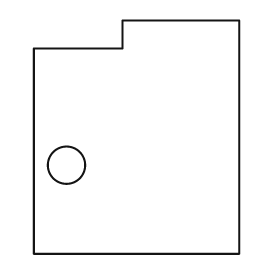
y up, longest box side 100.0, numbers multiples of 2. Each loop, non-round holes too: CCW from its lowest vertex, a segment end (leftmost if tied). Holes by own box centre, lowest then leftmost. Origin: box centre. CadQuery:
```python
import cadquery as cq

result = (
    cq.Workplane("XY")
    .moveTo(-44.0, -50.0)
    .lineTo(44.0, -50.0)
    .lineTo(44.0, 50.0)
    .lineTo(-6.0, 50.0)
    .lineTo(-6.0, 38.0)
    .lineTo(-44.0, 38.0)
    .close()
    .moveTo(-30.0, -12.0)
    .circle(8.0)
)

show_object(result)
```